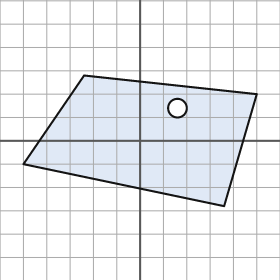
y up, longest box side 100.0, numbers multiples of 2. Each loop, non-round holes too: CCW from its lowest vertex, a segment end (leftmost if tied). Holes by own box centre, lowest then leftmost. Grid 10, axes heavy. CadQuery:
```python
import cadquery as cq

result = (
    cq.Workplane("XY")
    .moveTo(36.0, -28.0)
    .lineTo(50.0, 20.0)
    .lineTo(-24.0, 28.0)
    .lineTo(-50.0, -10.0)
    .close()
    .moveTo(16.0, 14.0)
    .circle(4.0)
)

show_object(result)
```